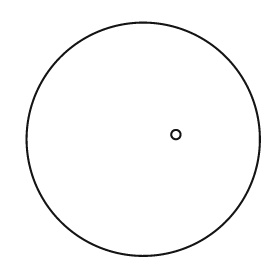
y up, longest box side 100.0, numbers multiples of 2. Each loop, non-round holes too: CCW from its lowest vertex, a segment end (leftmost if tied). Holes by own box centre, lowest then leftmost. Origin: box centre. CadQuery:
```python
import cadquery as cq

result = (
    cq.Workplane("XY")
    .moveTo(0.0, 0.0)
    .circle(50.0)
    .moveTo(14.0, 2.0)
    .circle(2.0)
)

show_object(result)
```